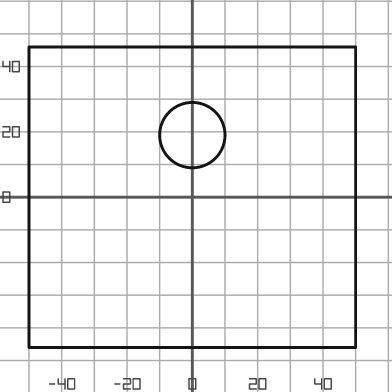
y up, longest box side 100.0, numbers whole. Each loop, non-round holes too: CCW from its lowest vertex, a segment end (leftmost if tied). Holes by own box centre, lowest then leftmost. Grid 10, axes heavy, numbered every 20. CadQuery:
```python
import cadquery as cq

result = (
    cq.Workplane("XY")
    .moveTo(-50.0, -46.0)
    .lineTo(50.0, -46.0)
    .lineTo(50.0, 46.0)
    .lineTo(-50.0, 46.0)
    .close()
    .moveTo(0.0, 19.0)
    .circle(10.0)
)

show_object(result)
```